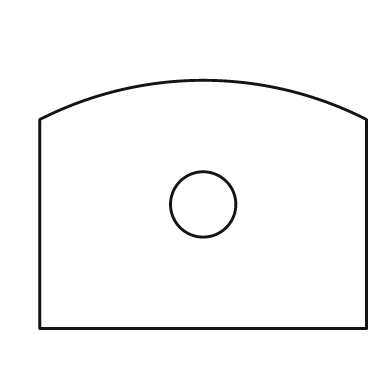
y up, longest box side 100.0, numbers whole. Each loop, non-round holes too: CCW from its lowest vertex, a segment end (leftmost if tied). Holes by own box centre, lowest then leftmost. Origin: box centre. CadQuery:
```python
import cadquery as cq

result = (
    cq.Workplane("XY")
    .moveTo(-50.0, -38.0)
    .lineTo(50.0, -38.0)
    .lineTo(50.0, 26.0)
    .threePointArc((0.0, 38.0), (-50.0, 26.0))
    .close()
    .moveTo(0.0, 0.0)
    .circle(10.0)
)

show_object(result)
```